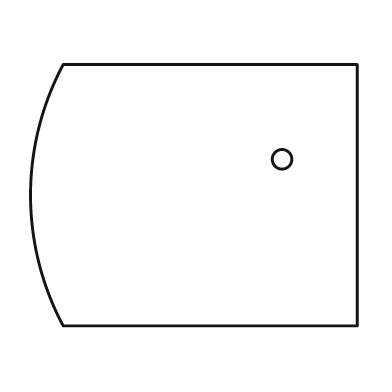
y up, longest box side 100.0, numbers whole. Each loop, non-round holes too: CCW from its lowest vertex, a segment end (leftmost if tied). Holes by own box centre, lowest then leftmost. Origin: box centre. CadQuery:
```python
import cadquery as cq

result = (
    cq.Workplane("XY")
    .moveTo(-40.0, -40.0)
    .lineTo(50.0, -40.0)
    .lineTo(50.0, 40.0)
    .lineTo(-40.0, 40.0)
    .threePointArc((-50.0, 0.0), (-40.0, -40.0))
    .close()
    .moveTo(27.0, 11.0)
    .circle(3.0)
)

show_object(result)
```